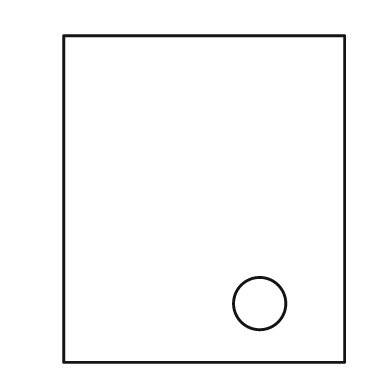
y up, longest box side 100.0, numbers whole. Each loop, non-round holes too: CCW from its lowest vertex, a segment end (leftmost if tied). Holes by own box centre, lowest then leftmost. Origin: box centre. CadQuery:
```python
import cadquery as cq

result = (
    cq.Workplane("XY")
    .moveTo(-43.0, -50.0)
    .lineTo(43.0, -50.0)
    .lineTo(43.0, 50.0)
    .lineTo(-43.0, 50.0)
    .close()
    .moveTo(17.0, -32.0)
    .circle(8.0)
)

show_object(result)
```